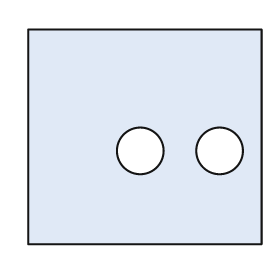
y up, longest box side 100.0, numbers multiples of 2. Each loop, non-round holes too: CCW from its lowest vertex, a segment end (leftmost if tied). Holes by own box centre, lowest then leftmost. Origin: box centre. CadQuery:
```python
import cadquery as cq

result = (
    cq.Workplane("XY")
    .moveTo(-50.0, -46.0)
    .lineTo(50.0, -46.0)
    .lineTo(50.0, 46.0)
    .lineTo(-50.0, 46.0)
    .close()
    .moveTo(-2.0, -6.0)
    .circle(10.0)
    .moveTo(32.0, -6.0)
    .circle(10.0)
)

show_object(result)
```